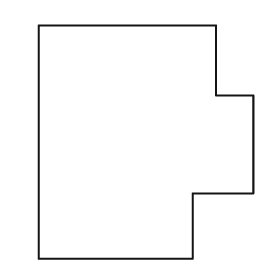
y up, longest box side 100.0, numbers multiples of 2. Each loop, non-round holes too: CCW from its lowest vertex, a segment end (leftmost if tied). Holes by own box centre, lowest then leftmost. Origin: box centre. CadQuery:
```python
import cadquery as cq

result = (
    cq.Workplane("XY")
    .moveTo(-46.0, -50.0)
    .lineTo(20.0, -50.0)
    .lineTo(20.0, -22.0)
    .lineTo(46.0, -22.0)
    .lineTo(46.0, 20.0)
    .lineTo(30.0, 20.0)
    .lineTo(30.0, 50.0)
    .lineTo(-46.0, 50.0)
    .close()
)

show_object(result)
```